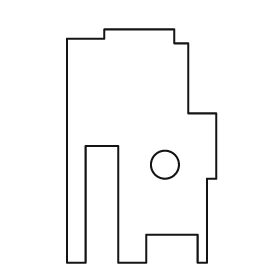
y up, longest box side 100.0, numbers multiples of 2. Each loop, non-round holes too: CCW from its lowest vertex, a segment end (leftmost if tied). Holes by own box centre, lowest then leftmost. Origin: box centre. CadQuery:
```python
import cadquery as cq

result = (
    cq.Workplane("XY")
    .moveTo(-32.0, -50.0)
    .lineTo(-24.0, -50.0)
    .lineTo(-24.0, 0.0)
    .lineTo(-10.0, 0.0)
    .lineTo(-10.0, -50.0)
    .lineTo(2.0, -50.0)
    .lineTo(2.0, -38.0)
    .lineTo(24.0, -38.0)
    .lineTo(24.0, -50.0)
    .lineTo(28.0, -50.0)
    .lineTo(28.0, -14.0)
    .lineTo(32.0, -14.0)
    .lineTo(32.0, 14.0)
    .lineTo(20.0, 14.0)
    .lineTo(20.0, 44.0)
    .lineTo(14.0, 44.0)
    .lineTo(14.0, 50.0)
    .lineTo(-16.0, 50.0)
    .lineTo(-16.0, 46.0)
    .lineTo(-32.0, 46.0)
    .close()
    .moveTo(10.0, -8.0)
    .circle(6.0)
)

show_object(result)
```